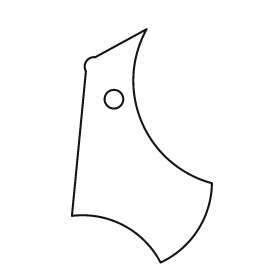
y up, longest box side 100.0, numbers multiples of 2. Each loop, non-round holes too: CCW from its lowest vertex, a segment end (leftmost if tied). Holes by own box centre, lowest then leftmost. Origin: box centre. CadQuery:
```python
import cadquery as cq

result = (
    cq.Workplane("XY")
    .moveTo(8.0, -50.0)
    .threePointArc((24.0, -36.0), (30.0, -16.0))
    .threePointArc((0.0, 10.0), (2.0, 50.0))
    .lineTo(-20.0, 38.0)
    .threePointArc((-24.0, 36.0), (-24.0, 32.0))
    .lineTo(-30.0, -30.0)
    .threePointArc((-8.0, -34.0), (8.0, -50.0))
    .close()
    .moveTo(-12.0, 20.0)
    .circle(4.0)
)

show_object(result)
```